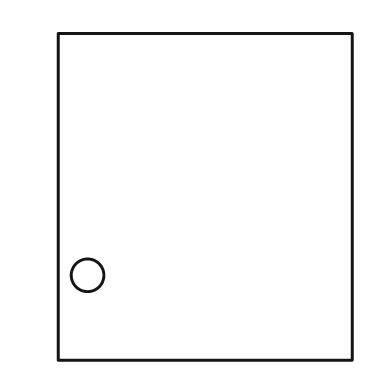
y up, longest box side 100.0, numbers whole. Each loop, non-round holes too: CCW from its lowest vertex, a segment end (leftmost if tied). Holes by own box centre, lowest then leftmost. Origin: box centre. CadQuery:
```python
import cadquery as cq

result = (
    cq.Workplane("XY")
    .moveTo(-45.0, -50.0)
    .lineTo(45.0, -50.0)
    .lineTo(45.0, 50.0)
    .lineTo(-45.0, 50.0)
    .close()
    .moveTo(-36.0, -24.0)
    .circle(5.0)
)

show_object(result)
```